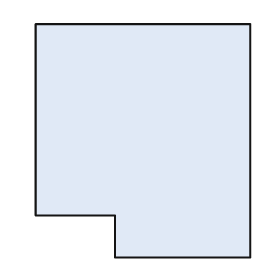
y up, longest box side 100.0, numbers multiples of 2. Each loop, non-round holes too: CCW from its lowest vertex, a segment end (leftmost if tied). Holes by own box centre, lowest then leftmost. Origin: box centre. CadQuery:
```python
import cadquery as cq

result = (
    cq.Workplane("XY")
    .moveTo(-12.0, -50.0)
    .lineTo(46.0, -50.0)
    .lineTo(46.0, 50.0)
    .lineTo(-46.0, 50.0)
    .lineTo(-46.0, -32.0)
    .lineTo(-12.0, -32.0)
    .close()
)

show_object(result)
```